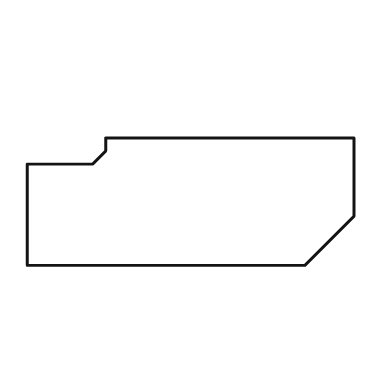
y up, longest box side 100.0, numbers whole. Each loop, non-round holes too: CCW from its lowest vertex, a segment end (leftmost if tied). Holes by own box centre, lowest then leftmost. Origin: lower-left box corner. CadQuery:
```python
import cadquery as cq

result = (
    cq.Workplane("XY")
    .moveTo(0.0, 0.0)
    .lineTo(85.0, 0.0)
    .lineTo(100.0, 15.0)
    .lineTo(100.0, 39.0)
    .lineTo(24.0, 39.0)
    .lineTo(24.0, 35.0)
    .lineTo(20.0, 31.0)
    .lineTo(0.0, 31.0)
    .close()
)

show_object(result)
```